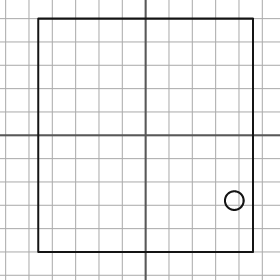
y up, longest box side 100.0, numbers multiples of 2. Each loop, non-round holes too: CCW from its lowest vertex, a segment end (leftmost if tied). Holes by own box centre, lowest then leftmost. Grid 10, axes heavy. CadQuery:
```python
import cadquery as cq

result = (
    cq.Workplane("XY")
    .moveTo(-46.0, -50.0)
    .lineTo(46.0, -50.0)
    .lineTo(46.0, 50.0)
    .lineTo(-46.0, 50.0)
    .close()
    .moveTo(38.0, -28.0)
    .circle(4.0)
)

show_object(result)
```